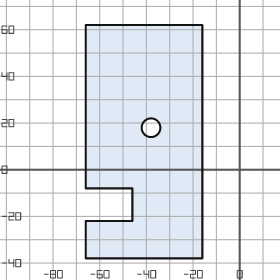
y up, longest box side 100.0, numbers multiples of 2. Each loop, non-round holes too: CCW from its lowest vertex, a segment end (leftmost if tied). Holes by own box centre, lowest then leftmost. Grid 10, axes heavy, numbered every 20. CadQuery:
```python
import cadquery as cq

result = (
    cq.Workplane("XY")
    .moveTo(-66.0, -38.0)
    .lineTo(-16.0, -38.0)
    .lineTo(-16.0, 62.0)
    .lineTo(-66.0, 62.0)
    .lineTo(-66.0, -8.0)
    .lineTo(-46.0, -8.0)
    .lineTo(-46.0, -22.0)
    .lineTo(-66.0, -22.0)
    .close()
    .moveTo(-38.0, 18.0)
    .circle(4.0)
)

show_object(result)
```